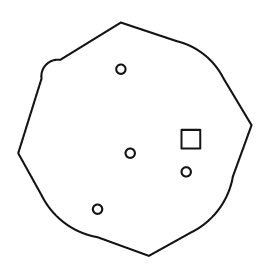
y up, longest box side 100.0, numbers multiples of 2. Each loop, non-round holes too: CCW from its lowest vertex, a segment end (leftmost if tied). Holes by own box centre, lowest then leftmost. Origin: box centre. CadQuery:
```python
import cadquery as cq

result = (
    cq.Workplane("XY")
    .moveTo(6.0, -50.0)
    .lineTo(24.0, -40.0)
    .threePointArc((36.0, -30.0), (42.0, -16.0))
    .lineTo(50.0, 6.0)
    .lineTo(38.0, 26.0)
    .threePointArc((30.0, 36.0), (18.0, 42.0))
    .lineTo(-6.0, 50.0)
    .lineTo(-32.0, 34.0)
    .threePointArc((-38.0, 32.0), (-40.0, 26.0))
    .lineTo(-50.0, -6.0)
    .lineTo(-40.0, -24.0)
    .threePointArc((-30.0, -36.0), (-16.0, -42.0))
    .close()
    .moveTo(-16.0, -30.0)
    .circle(2.0)
    .moveTo(22.0, -14.0)
    .circle(2.0)
    .moveTo(-2.0, -6.0)
    .circle(2.0)
    .moveTo(20.0, -4.0)
    .lineTo(28.0, -4.0)
    .lineTo(28.0, 4.0)
    .lineTo(20.0, 4.0)
    .close()
    .moveTo(-6.0, 30.0)
    .circle(2.0)
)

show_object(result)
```